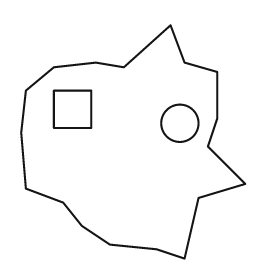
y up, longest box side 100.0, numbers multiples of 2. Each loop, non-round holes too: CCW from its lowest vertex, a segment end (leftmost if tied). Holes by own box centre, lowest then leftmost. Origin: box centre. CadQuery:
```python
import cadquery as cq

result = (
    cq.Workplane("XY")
    .moveTo(22.0, -50.0)
    .lineTo(28.0, -24.0)
    .lineTo(48.0, -18.0)
    .lineTo(32.0, -2.0)
    .lineTo(36.0, 10.0)
    .lineTo(36.0, 30.0)
    .lineTo(22.0, 34.0)
    .lineTo(16.0, 50.0)
    .lineTo(-4.0, 32.0)
    .lineTo(-16.0, 34.0)
    .lineTo(-34.0, 32.0)
    .lineTo(-46.0, 22.0)
    .lineTo(-48.0, 4.0)
    .lineTo(-46.0, -20.0)
    .lineTo(-30.0, -26.0)
    .lineTo(-22.0, -36.0)
    .lineTo(-10.0, -44.0)
    .lineTo(10.0, -46.0)
    .close()
    .moveTo(20.0, 8.0)
    .circle(8.0)
    .moveTo(-34.0, 6.0)
    .lineTo(-18.0, 6.0)
    .lineTo(-18.0, 22.0)
    .lineTo(-34.0, 22.0)
    .close()
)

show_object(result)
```